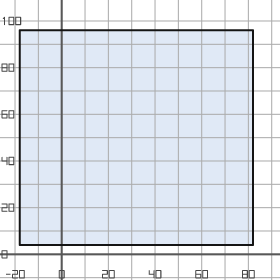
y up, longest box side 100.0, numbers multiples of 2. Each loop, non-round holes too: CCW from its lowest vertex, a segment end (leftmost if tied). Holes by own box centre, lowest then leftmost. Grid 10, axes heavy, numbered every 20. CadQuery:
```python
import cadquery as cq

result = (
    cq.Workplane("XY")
    .moveTo(-18.0, 4.0)
    .lineTo(82.0, 4.0)
    .lineTo(82.0, 96.0)
    .lineTo(-18.0, 96.0)
    .close()
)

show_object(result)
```